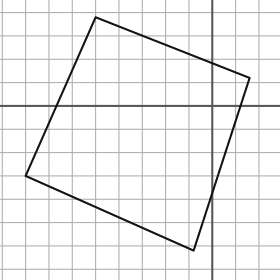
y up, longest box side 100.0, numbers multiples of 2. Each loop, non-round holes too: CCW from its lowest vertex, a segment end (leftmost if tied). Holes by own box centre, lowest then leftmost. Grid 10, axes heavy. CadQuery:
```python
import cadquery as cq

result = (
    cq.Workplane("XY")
    .moveTo(-8.0, -62.0)
    .lineTo(16.0, 12.0)
    .lineTo(-50.0, 38.0)
    .lineTo(-80.0, -30.0)
    .close()
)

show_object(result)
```